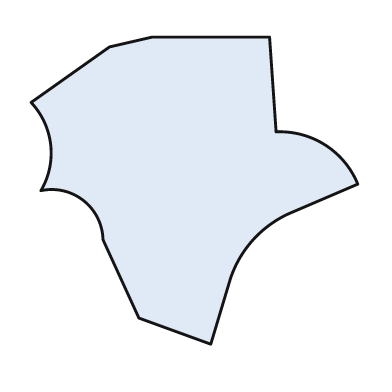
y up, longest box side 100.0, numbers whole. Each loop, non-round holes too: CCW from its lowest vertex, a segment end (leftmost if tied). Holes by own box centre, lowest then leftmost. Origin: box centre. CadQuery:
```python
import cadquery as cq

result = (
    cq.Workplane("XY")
    .moveTo(5.0, -47.0)
    .lineTo(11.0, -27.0)
    .threePointArc((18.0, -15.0), (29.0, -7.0))
    .lineTo(50.0, 2.0)
    .threePointArc((40.0, 14.0), (25.0, 18.0))
    .lineTo(23.0, 47.0)
    .lineTo(-13.0, 47.0)
    .lineTo(-26.0, 44.0)
    .lineTo(-50.0, 27.0)
    .threePointArc((-44.0, 14.0), (-47.0, 0.0))
    .threePointArc((-34.0, -3.0), (-28.0, -15.0))
    .lineTo(-17.0, -39.0)
    .close()
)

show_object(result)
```